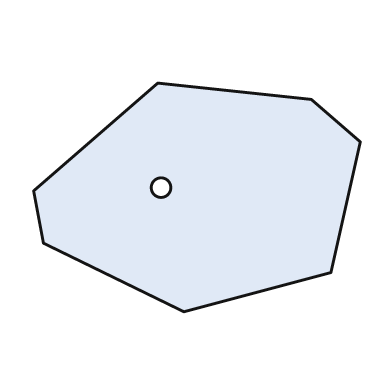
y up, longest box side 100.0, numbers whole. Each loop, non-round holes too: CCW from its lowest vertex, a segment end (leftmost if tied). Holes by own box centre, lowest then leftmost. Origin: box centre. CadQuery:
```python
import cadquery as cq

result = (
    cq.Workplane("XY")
    .moveTo(-4.0, -35.0)
    .lineTo(41.0, -23.0)
    .lineTo(50.0, 17.0)
    .lineTo(35.0, 30.0)
    .lineTo(-12.0, 35.0)
    .lineTo(-50.0, 2.0)
    .lineTo(-47.0, -14.0)
    .close()
    .moveTo(-11.0, 3.0)
    .circle(3.0)
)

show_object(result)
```